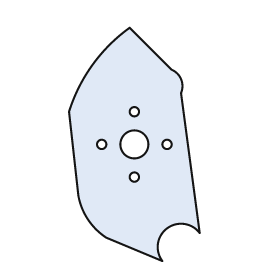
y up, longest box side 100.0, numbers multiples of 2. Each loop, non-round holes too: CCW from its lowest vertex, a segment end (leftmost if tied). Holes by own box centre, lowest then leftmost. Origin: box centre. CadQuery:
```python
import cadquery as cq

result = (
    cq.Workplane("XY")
    .moveTo(12.0, -50.0)
    .threePointArc((14.0, -36.0), (28.0, -38.0))
    .lineTo(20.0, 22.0)
    .threePointArc((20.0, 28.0), (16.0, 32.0))
    .lineTo(-2.0, 50.0)
    .threePointArc((-18.0, 34.0), (-28.0, 14.0))
    .lineTo(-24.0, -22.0)
    .threePointArc((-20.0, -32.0), (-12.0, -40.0))
    .close()
    .moveTo(0.0, -14.0)
    .circle(2.0)
    .moveTo(-14.0, 0.0)
    .circle(2.0)
    .moveTo(0.0, 0.0)
    .circle(6.0)
    .moveTo(14.0, 0.0)
    .circle(2.0)
    .moveTo(0.0, 14.0)
    .circle(2.0)
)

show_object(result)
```